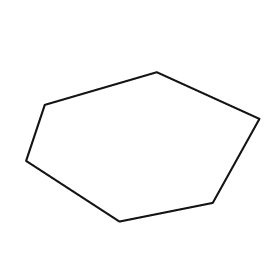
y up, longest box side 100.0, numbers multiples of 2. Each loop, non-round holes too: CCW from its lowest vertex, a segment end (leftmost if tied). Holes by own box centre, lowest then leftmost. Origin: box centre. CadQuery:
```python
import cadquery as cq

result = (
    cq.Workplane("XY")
    .moveTo(-10.0, -32.0)
    .lineTo(30.0, -24.0)
    .lineTo(50.0, 12.0)
    .lineTo(6.0, 32.0)
    .lineTo(-42.0, 18.0)
    .lineTo(-50.0, -6.0)
    .close()
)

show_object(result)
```